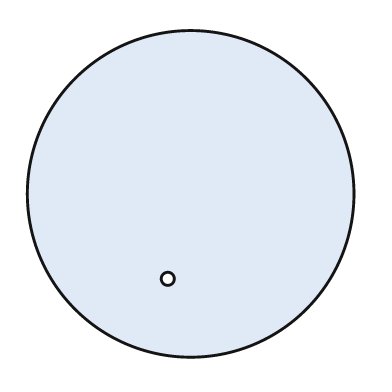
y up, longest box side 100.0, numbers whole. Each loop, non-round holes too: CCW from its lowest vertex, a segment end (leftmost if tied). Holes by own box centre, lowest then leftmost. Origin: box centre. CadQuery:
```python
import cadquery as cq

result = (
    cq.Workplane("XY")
    .moveTo(0.0, 0.0)
    .circle(50.0)
    .moveTo(-7.0, -26.0)
    .circle(2.0)
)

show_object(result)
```